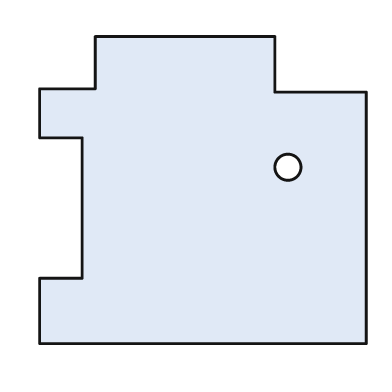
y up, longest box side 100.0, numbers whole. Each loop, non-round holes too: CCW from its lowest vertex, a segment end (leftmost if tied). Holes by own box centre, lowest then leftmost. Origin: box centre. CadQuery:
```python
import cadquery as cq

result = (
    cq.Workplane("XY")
    .moveTo(-50.0, -47.0)
    .lineTo(50.0, -47.0)
    .lineTo(50.0, 30.0)
    .lineTo(22.0, 30.0)
    .lineTo(22.0, 47.0)
    .lineTo(-33.0, 47.0)
    .lineTo(-33.0, 31.0)
    .lineTo(-50.0, 31.0)
    .lineTo(-50.0, 16.0)
    .lineTo(-37.0, 16.0)
    .lineTo(-37.0, -27.0)
    .lineTo(-50.0, -27.0)
    .close()
    .moveTo(26.0, 7.0)
    .circle(4.0)
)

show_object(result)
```